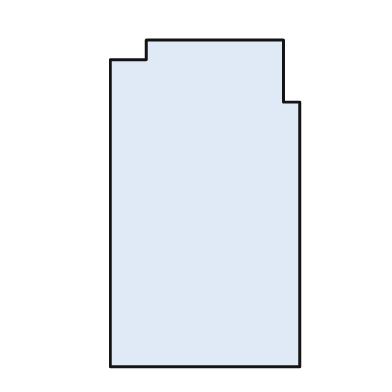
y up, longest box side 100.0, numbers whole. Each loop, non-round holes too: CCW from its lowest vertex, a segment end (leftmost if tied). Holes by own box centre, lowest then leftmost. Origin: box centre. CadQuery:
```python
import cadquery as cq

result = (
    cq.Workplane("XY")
    .moveTo(-29.0, -50.0)
    .lineTo(29.0, -50.0)
    .lineTo(29.0, 31.0)
    .lineTo(24.0, 31.0)
    .lineTo(24.0, 50.0)
    .lineTo(-18.0, 50.0)
    .lineTo(-18.0, 44.0)
    .lineTo(-29.0, 44.0)
    .close()
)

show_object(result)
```